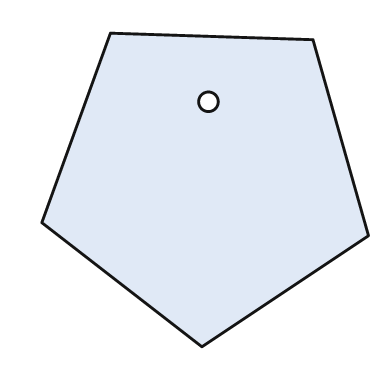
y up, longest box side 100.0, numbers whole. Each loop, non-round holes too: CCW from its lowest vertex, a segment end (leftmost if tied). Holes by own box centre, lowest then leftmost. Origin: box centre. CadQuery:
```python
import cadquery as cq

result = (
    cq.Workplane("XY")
    .moveTo(-1.0, -48.0)
    .lineTo(50.0, -14.0)
    .lineTo(33.0, 46.0)
    .lineTo(-29.0, 48.0)
    .lineTo(-50.0, -10.0)
    .close()
    .moveTo(1.0, 27.0)
    .circle(3.0)
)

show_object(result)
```